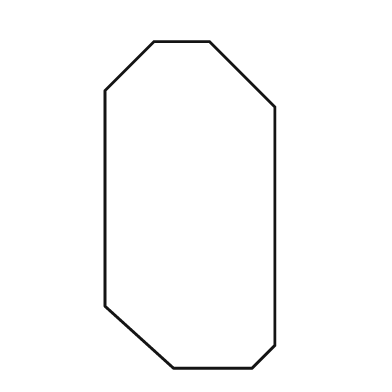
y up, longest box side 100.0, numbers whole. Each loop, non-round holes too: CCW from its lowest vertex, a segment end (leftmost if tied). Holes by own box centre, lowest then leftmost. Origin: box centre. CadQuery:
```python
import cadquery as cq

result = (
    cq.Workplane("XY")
    .moveTo(-5.0, -50.0)
    .lineTo(19.0, -50.0)
    .lineTo(26.0, -43.0)
    .lineTo(26.0, 30.0)
    .lineTo(6.0, 50.0)
    .lineTo(-11.0, 50.0)
    .lineTo(-26.0, 35.0)
    .lineTo(-26.0, -31.0)
    .close()
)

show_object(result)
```